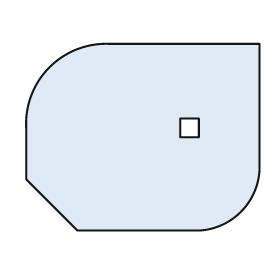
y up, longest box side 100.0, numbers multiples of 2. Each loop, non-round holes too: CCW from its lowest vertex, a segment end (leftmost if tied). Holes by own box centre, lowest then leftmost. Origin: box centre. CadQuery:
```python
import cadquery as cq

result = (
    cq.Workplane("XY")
    .moveTo(-28.0, -40.0)
    .lineTo(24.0, -40.0)
    .threePointArc((42.0, -32.0), (50.0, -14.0))
    .lineTo(50.0, 40.0)
    .lineTo(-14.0, 40.0)
    .threePointArc((-40.0, 30.0), (-50.0, 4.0))
    .lineTo(-50.0, -18.0)
    .close()
    .moveTo(16.0, 0.0)
    .lineTo(24.0, 0.0)
    .lineTo(24.0, 8.0)
    .lineTo(16.0, 8.0)
    .close()
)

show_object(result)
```